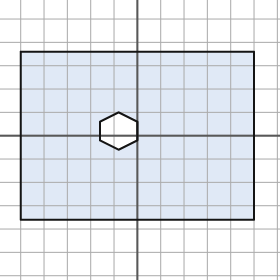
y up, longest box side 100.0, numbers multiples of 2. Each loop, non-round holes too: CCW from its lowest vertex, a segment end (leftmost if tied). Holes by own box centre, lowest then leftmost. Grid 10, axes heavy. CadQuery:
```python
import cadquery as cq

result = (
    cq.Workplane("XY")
    .moveTo(-50.0, -36.0)
    .lineTo(50.0, -36.0)
    .lineTo(50.0, 36.0)
    .lineTo(-50.0, 36.0)
    .close()
    .moveTo(-8.0, -6.0)
    .lineTo(0.0, -2.0)
    .lineTo(0.0, 6.0)
    .lineTo(-8.0, 10.0)
    .lineTo(-16.0, 6.0)
    .lineTo(-16.0, -2.0)
    .close()
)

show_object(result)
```